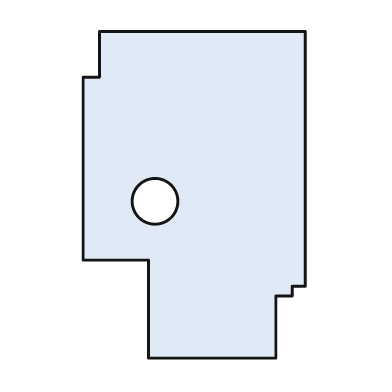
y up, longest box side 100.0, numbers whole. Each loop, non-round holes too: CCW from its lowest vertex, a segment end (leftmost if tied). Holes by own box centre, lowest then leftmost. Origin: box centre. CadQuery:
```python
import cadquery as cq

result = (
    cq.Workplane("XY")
    .moveTo(-14.0, -50.0)
    .lineTo(25.0, -50.0)
    .lineTo(25.0, -31.0)
    .lineTo(30.0, -31.0)
    .lineTo(30.0, -28.0)
    .lineTo(34.0, -28.0)
    .lineTo(34.0, 50.0)
    .lineTo(-29.0, 50.0)
    .lineTo(-29.0, 36.0)
    .lineTo(-34.0, 36.0)
    .lineTo(-34.0, -20.0)
    .lineTo(-14.0, -20.0)
    .close()
    .moveTo(-12.0, -2.0)
    .circle(7.0)
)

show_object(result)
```